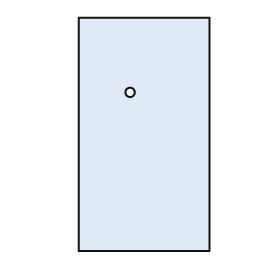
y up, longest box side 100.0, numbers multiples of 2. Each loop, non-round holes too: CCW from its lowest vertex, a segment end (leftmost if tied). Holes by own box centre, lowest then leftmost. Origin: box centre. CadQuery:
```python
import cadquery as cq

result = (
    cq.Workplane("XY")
    .moveTo(-28.0, -50.0)
    .lineTo(28.0, -50.0)
    .lineTo(28.0, 50.0)
    .lineTo(-28.0, 50.0)
    .close()
    .moveTo(-6.0, 18.0)
    .circle(2.0)
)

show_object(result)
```